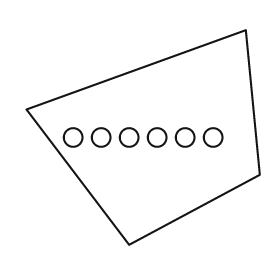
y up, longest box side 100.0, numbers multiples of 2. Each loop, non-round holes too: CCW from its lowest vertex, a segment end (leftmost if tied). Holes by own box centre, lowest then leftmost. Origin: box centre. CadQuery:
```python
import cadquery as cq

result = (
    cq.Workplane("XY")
    .moveTo(-6.0, -46.0)
    .lineTo(50.0, -16.0)
    .lineTo(44.0, 46.0)
    .lineTo(-50.0, 12.0)
    .close()
    .moveTo(-30.0, 0.0)
    .circle(4.0)
    .moveTo(-18.0, 0.0)
    .circle(4.0)
    .moveTo(-6.0, 0.0)
    .circle(4.0)
    .moveTo(6.0, 0.0)
    .circle(4.0)
    .moveTo(18.0, 0.0)
    .circle(4.0)
    .moveTo(30.0, 0.0)
    .circle(4.0)
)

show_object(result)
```